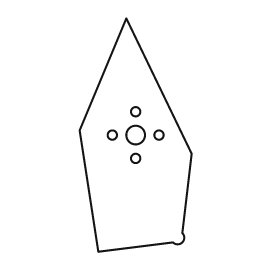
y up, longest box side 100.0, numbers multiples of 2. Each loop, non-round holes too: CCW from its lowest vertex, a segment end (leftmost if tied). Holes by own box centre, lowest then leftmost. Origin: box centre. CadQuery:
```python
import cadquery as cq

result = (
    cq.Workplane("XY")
    .moveTo(-16.0, -50.0)
    .lineTo(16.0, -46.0)
    .threePointArc((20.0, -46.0), (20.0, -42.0))
    .lineTo(24.0, -8.0)
    .lineTo(-4.0, 50.0)
    .lineTo(-24.0, 2.0)
    .close()
    .moveTo(0.0, -10.0)
    .circle(2.0)
    .moveTo(-10.0, 0.0)
    .circle(2.0)
    .moveTo(0.0, 0.0)
    .circle(4.0)
    .moveTo(10.0, 0.0)
    .circle(2.0)
    .moveTo(0.0, 10.0)
    .circle(2.0)
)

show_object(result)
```